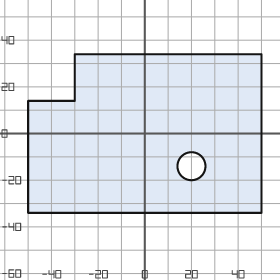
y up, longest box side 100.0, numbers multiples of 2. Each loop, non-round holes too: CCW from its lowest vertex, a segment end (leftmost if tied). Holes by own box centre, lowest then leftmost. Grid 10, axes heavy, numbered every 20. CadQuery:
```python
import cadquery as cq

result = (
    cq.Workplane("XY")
    .moveTo(-50.0, -34.0)
    .lineTo(50.0, -34.0)
    .lineTo(50.0, 34.0)
    .lineTo(-30.0, 34.0)
    .lineTo(-30.0, 14.0)
    .lineTo(-50.0, 14.0)
    .close()
    .moveTo(20.0, -14.0)
    .circle(6.0)
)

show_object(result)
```